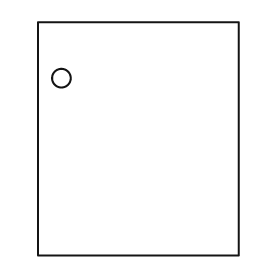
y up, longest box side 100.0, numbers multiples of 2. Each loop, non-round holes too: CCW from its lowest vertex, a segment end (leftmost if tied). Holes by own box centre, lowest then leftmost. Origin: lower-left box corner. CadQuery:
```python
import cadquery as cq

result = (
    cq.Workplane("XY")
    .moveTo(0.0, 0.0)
    .lineTo(86.0, 0.0)
    .lineTo(86.0, 100.0)
    .lineTo(0.0, 100.0)
    .close()
    .moveTo(10.0, 76.0)
    .circle(4.0)
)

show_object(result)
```